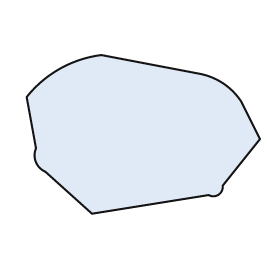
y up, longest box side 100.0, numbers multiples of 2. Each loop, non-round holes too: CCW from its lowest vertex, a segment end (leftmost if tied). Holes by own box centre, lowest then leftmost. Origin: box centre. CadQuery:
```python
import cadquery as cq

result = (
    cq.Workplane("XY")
    .moveTo(-22.0, -34.0)
    .lineTo(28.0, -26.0)
    .threePointArc((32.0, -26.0), (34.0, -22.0))
    .lineTo(50.0, -2.0)
    .lineTo(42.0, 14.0)
    .threePointArc((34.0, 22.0), (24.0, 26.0))
    .lineTo(-18.0, 34.0)
    .threePointArc((-36.0, 28.0), (-50.0, 16.0))
    .lineTo(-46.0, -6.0)
    .threePointArc((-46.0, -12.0), (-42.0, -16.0))
    .close()
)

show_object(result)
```